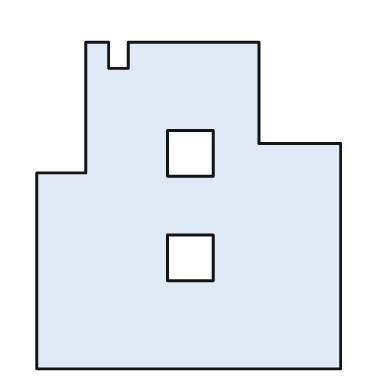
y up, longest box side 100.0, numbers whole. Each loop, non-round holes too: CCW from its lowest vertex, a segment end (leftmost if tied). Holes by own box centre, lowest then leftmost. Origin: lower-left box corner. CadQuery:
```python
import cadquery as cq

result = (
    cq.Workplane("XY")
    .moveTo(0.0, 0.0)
    .lineTo(93.0, 0.0)
    .lineTo(93.0, 69.0)
    .lineTo(68.0, 69.0)
    .lineTo(68.0, 100.0)
    .lineTo(28.0, 100.0)
    .lineTo(28.0, 92.0)
    .lineTo(22.0, 92.0)
    .lineTo(22.0, 100.0)
    .lineTo(15.0, 100.0)
    .lineTo(15.0, 60.0)
    .lineTo(0.0, 60.0)
    .close()
    .moveTo(40.0, 27.0)
    .lineTo(54.0, 27.0)
    .lineTo(54.0, 41.0)
    .lineTo(40.0, 41.0)
    .close()
    .moveTo(40.0, 59.0)
    .lineTo(54.0, 59.0)
    .lineTo(54.0, 73.0)
    .lineTo(40.0, 73.0)
    .close()
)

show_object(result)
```